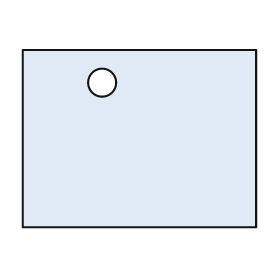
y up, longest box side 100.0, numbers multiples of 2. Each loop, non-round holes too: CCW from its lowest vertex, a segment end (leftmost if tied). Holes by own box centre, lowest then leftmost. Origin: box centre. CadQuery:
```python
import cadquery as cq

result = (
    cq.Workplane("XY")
    .moveTo(-50.0, -38.0)
    .lineTo(50.0, -38.0)
    .lineTo(50.0, 38.0)
    .lineTo(-50.0, 38.0)
    .close()
    .moveTo(-16.0, 24.0)
    .circle(6.0)
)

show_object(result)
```